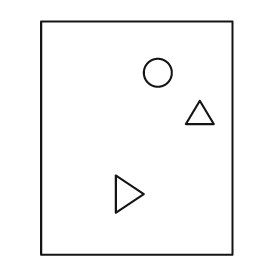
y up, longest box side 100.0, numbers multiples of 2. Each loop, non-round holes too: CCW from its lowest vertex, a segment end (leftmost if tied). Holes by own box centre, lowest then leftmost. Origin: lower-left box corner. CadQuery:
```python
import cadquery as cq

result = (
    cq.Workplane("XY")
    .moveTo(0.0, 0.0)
    .lineTo(82.0, 0.0)
    .lineTo(82.0, 100.0)
    .lineTo(0.0, 100.0)
    .close()
    .moveTo(32.0, 18.0)
    .lineTo(44.0, 26.0)
    .lineTo(32.0, 34.0)
    .close()
    .moveTo(62.0, 56.0)
    .lineTo(74.0, 56.0)
    .lineTo(68.0, 66.0)
    .close()
    .moveTo(50.0, 78.0)
    .circle(6.0)
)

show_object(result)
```